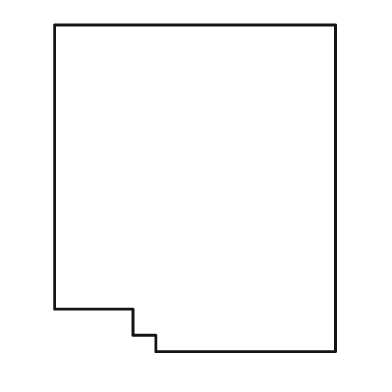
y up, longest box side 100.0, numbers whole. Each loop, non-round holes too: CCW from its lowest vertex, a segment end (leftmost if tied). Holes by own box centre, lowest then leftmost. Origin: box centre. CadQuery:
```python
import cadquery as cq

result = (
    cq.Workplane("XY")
    .moveTo(-12.0, -50.0)
    .lineTo(43.0, -50.0)
    .lineTo(43.0, 50.0)
    .lineTo(-43.0, 50.0)
    .lineTo(-43.0, -37.0)
    .lineTo(-19.0, -37.0)
    .lineTo(-19.0, -45.0)
    .lineTo(-12.0, -45.0)
    .close()
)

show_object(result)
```